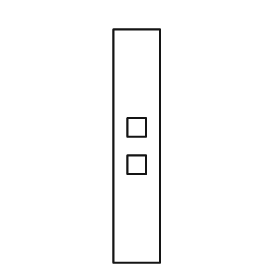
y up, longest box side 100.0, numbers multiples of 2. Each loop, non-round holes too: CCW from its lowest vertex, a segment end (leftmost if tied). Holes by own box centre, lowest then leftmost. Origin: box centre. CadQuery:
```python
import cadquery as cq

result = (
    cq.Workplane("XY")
    .moveTo(-10.0, -50.0)
    .lineTo(10.0, -50.0)
    .lineTo(10.0, 50.0)
    .lineTo(-10.0, 50.0)
    .close()
    .moveTo(-4.0, -12.0)
    .lineTo(4.0, -12.0)
    .lineTo(4.0, -4.0)
    .lineTo(-4.0, -4.0)
    .close()
    .moveTo(-4.0, 4.0)
    .lineTo(4.0, 4.0)
    .lineTo(4.0, 12.0)
    .lineTo(-4.0, 12.0)
    .close()
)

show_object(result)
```